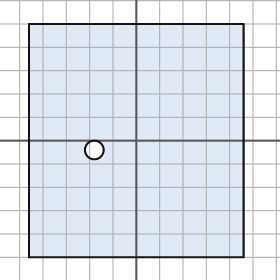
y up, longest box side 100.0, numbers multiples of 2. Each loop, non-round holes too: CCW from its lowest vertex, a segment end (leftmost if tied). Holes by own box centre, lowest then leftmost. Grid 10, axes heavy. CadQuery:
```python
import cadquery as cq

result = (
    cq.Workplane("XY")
    .moveTo(-46.0, -50.0)
    .lineTo(46.0, -50.0)
    .lineTo(46.0, 50.0)
    .lineTo(-46.0, 50.0)
    .close()
    .moveTo(-18.0, -4.0)
    .circle(4.0)
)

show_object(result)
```